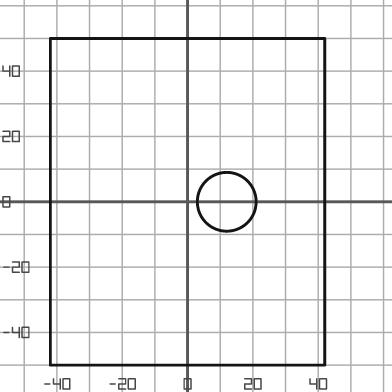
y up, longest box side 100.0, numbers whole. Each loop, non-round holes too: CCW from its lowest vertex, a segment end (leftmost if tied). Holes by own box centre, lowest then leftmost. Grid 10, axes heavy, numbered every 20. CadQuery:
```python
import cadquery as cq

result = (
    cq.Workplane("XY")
    .moveTo(-42.0, -50.0)
    .lineTo(42.0, -50.0)
    .lineTo(42.0, 50.0)
    .lineTo(-42.0, 50.0)
    .close()
    .moveTo(12.0, 0.0)
    .circle(9.0)
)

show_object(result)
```